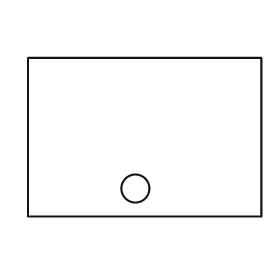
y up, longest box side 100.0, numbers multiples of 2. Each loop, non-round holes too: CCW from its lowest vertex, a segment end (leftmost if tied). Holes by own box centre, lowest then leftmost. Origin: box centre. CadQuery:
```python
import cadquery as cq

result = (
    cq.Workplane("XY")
    .moveTo(-50.0, -34.0)
    .lineTo(50.0, -34.0)
    .lineTo(50.0, 34.0)
    .lineTo(-50.0, 34.0)
    .close()
    .moveTo(-4.0, -22.0)
    .circle(6.0)
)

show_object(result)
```